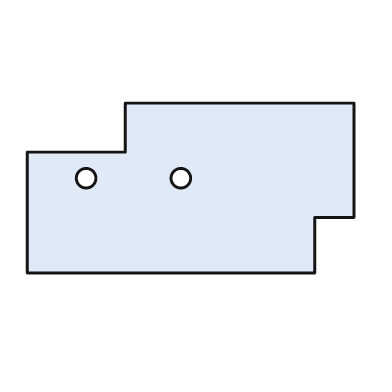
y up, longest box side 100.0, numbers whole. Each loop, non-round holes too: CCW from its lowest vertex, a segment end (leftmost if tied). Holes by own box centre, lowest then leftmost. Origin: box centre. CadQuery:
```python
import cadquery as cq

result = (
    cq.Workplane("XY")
    .moveTo(-50.0, -26.0)
    .lineTo(38.0, -26.0)
    .lineTo(38.0, -9.0)
    .lineTo(50.0, -9.0)
    .lineTo(50.0, 26.0)
    .lineTo(-20.0, 26.0)
    .lineTo(-20.0, 11.0)
    .lineTo(-50.0, 11.0)
    .close()
    .moveTo(-32.0, 3.0)
    .circle(3.0)
    .moveTo(-3.0, 3.0)
    .circle(3.0)
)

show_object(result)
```